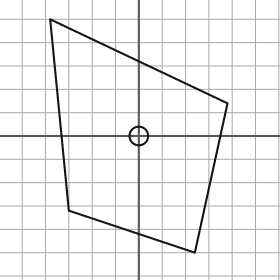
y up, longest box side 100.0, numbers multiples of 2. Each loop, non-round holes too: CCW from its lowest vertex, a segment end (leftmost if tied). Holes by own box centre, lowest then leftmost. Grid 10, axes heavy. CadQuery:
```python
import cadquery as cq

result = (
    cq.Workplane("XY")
    .moveTo(24.0, -50.0)
    .lineTo(38.0, 14.0)
    .lineTo(-38.0, 50.0)
    .lineTo(-30.0, -32.0)
    .close()
    .moveTo(0.0, 0.0)
    .circle(4.0)
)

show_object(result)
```